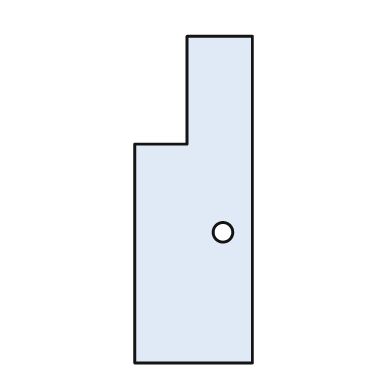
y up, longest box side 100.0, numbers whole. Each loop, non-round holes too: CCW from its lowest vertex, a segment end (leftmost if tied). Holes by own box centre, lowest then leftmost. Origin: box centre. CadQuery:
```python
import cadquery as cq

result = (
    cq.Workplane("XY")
    .moveTo(-18.0, -50.0)
    .lineTo(18.0, -50.0)
    .lineTo(18.0, 50.0)
    .lineTo(-2.0, 50.0)
    .lineTo(-2.0, 17.0)
    .lineTo(-18.0, 17.0)
    .close()
    .moveTo(9.0, -10.0)
    .circle(3.0)
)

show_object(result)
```